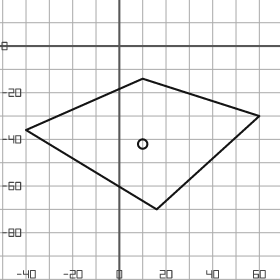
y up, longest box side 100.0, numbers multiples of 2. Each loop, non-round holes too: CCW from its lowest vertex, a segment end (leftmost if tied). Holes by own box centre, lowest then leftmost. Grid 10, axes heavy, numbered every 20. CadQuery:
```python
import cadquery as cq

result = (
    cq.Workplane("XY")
    .moveTo(16.0, -70.0)
    .lineTo(60.0, -30.0)
    .lineTo(10.0, -14.0)
    .lineTo(-40.0, -36.0)
    .close()
    .moveTo(10.0, -42.0)
    .circle(2.0)
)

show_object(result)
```